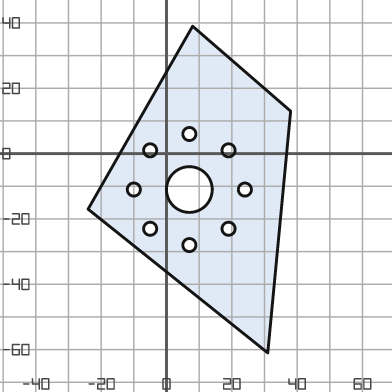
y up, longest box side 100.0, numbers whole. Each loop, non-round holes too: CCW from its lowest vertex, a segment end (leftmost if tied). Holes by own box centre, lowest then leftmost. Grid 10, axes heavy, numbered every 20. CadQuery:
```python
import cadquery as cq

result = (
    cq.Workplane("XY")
    .moveTo(31.0, -61.0)
    .lineTo(38.0, 13.0)
    .lineTo(8.0, 39.0)
    .lineTo(-24.0, -17.0)
    .close()
    .moveTo(7.0, -28.0)
    .circle(2.0)
    .moveTo(-5.0, -23.0)
    .circle(2.0)
    .moveTo(19.0, -23.0)
    .circle(2.0)
    .moveTo(-10.0, -11.0)
    .circle(2.0)
    .moveTo(7.0, -11.0)
    .circle(7.0)
    .moveTo(24.0, -11.0)
    .circle(2.0)
    .moveTo(-5.0, 1.0)
    .circle(2.0)
    .moveTo(19.0, 1.0)
    .circle(2.0)
    .moveTo(7.0, 6.0)
    .circle(2.0)
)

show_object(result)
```